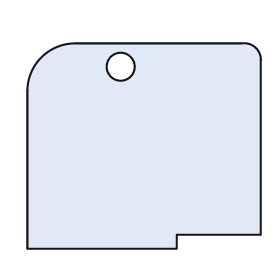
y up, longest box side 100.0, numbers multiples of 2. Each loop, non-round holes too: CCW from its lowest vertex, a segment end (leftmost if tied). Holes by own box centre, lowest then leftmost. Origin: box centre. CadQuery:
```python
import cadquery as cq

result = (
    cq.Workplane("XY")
    .moveTo(-50.0, -44.0)
    .lineTo(14.0, -44.0)
    .lineTo(14.0, -38.0)
    .lineTo(50.0, -38.0)
    .lineTo(50.0, 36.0)
    .threePointArc((48.0, 42.0), (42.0, 44.0))
    .lineTo(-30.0, 44.0)
    .threePointArc((-44.0, 38.0), (-50.0, 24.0))
    .close()
    .moveTo(-10.0, 34.0)
    .circle(6.0)
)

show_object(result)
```